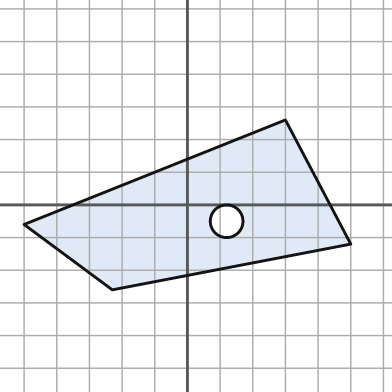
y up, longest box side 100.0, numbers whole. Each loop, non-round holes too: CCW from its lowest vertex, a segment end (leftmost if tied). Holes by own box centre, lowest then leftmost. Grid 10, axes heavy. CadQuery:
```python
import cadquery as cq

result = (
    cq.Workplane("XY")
    .moveTo(-23.0, -26.0)
    .lineTo(50.0, -12.0)
    .lineTo(30.0, 26.0)
    .lineTo(-50.0, -6.0)
    .close()
    .moveTo(12.0, -5.0)
    .circle(5.0)
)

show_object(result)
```